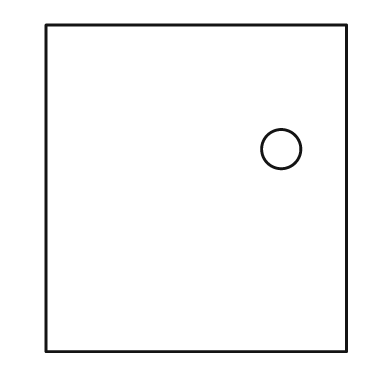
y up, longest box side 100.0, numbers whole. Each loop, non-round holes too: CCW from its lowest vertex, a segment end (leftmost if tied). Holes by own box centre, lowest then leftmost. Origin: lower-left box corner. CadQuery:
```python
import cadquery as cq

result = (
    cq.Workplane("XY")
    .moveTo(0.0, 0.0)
    .lineTo(92.0, 0.0)
    .lineTo(92.0, 100.0)
    .lineTo(0.0, 100.0)
    .close()
    .moveTo(72.0, 62.0)
    .circle(6.0)
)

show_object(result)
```